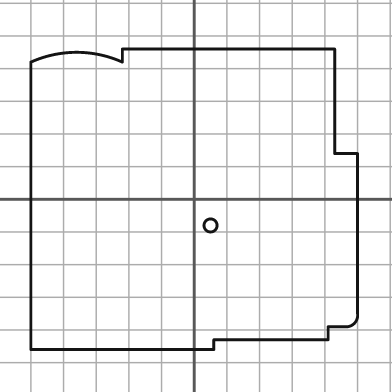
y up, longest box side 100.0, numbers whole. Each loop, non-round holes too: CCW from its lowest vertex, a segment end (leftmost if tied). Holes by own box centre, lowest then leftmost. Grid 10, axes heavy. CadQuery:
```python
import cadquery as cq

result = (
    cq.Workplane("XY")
    .moveTo(-50.0, -46.0)
    .lineTo(6.0, -46.0)
    .lineTo(6.0, -43.0)
    .lineTo(41.0, -43.0)
    .lineTo(41.0, -39.0)
    .lineTo(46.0, -39.0)
    .threePointArc((49.0, -38.0), (50.0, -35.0))
    .lineTo(50.0, 14.0)
    .lineTo(43.0, 14.0)
    .lineTo(43.0, 46.0)
    .lineTo(-22.0, 46.0)
    .lineTo(-22.0, 42.0)
    .threePointArc((-36.0, 45.0), (-50.0, 42.0))
    .close()
    .moveTo(5.0, -8.0)
    .circle(2.0)
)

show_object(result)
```